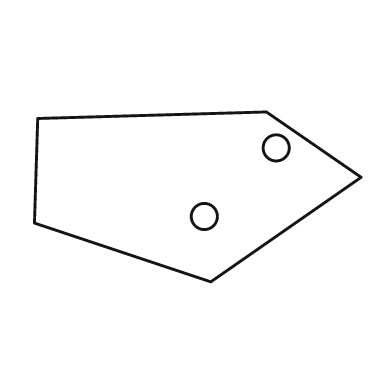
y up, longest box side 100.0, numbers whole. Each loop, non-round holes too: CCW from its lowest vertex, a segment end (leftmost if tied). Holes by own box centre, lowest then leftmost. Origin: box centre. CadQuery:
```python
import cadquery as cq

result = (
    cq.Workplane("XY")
    .moveTo(4.0, -26.0)
    .lineTo(50.0, 6.0)
    .lineTo(21.0, 26.0)
    .lineTo(-49.0, 24.0)
    .lineTo(-50.0, -8.0)
    .close()
    .moveTo(2.0, -6.0)
    .circle(4.0)
    .moveTo(24.0, 15.0)
    .circle(4.0)
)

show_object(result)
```